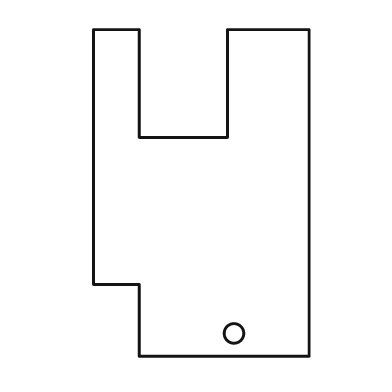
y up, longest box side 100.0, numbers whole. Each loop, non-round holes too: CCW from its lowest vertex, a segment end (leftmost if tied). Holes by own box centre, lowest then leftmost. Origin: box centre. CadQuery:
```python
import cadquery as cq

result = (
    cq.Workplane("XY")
    .moveTo(-19.0, -50.0)
    .lineTo(33.0, -50.0)
    .lineTo(33.0, 50.0)
    .lineTo(8.0, 50.0)
    .lineTo(8.0, 17.0)
    .lineTo(-19.0, 17.0)
    .lineTo(-19.0, 50.0)
    .lineTo(-33.0, 50.0)
    .lineTo(-33.0, -28.0)
    .lineTo(-19.0, -28.0)
    .close()
    .moveTo(10.0, -43.0)
    .circle(3.0)
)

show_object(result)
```